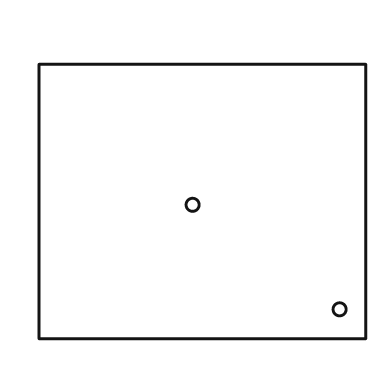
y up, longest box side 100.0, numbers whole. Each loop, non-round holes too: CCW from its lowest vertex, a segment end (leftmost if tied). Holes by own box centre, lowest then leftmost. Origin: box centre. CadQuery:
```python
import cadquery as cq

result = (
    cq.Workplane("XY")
    .moveTo(-50.0, -42.0)
    .lineTo(50.0, -42.0)
    .lineTo(50.0, 42.0)
    .lineTo(-50.0, 42.0)
    .close()
    .moveTo(42.0, -33.0)
    .circle(2.0)
    .moveTo(-3.0, -1.0)
    .circle(2.0)
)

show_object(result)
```